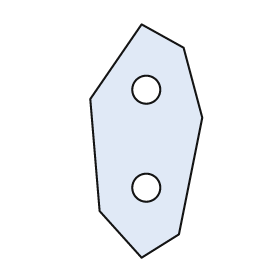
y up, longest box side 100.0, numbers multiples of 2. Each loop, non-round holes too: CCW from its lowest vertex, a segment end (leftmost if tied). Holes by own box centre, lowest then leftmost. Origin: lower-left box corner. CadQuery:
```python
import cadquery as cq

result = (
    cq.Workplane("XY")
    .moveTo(22.0, 0.0)
    .lineTo(38.0, 10.0)
    .lineTo(48.0, 60.0)
    .lineTo(40.0, 90.0)
    .lineTo(22.0, 100.0)
    .lineTo(0.0, 68.0)
    .lineTo(4.0, 20.0)
    .close()
    .moveTo(24.0, 30.0)
    .circle(6.0)
    .moveTo(24.0, 72.0)
    .circle(6.0)
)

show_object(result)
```